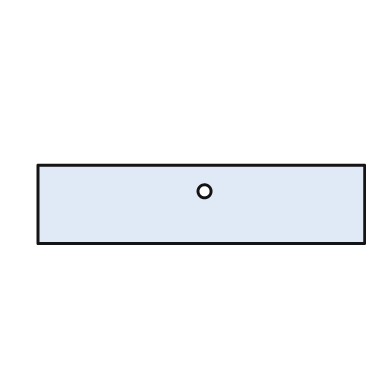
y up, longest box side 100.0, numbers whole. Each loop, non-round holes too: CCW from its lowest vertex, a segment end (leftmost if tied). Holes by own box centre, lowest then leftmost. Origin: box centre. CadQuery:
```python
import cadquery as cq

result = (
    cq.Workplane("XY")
    .moveTo(-50.0, -12.0)
    .lineTo(50.0, -12.0)
    .lineTo(50.0, 12.0)
    .lineTo(-50.0, 12.0)
    .close()
    .moveTo(1.0, 4.0)
    .circle(2.0)
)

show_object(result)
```